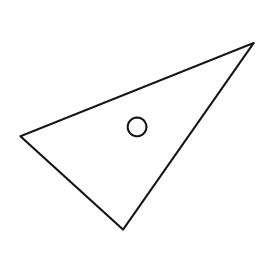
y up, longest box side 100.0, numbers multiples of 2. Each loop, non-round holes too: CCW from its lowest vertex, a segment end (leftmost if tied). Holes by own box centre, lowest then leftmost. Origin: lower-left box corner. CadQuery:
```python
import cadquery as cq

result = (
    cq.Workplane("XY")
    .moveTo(44.0, 0.0)
    .lineTo(100.0, 80.0)
    .lineTo(0.0, 40.0)
    .close()
    .moveTo(50.0, 44.0)
    .circle(4.0)
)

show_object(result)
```